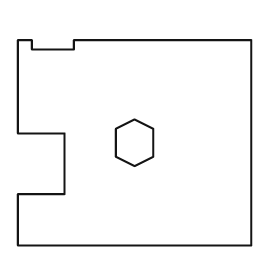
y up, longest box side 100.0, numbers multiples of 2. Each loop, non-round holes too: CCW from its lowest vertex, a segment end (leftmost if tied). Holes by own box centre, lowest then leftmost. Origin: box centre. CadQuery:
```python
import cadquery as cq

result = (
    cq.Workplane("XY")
    .moveTo(-50.0, -44.0)
    .lineTo(50.0, -44.0)
    .lineTo(50.0, 44.0)
    .lineTo(-26.0, 44.0)
    .lineTo(-26.0, 40.0)
    .lineTo(-44.0, 40.0)
    .lineTo(-44.0, 44.0)
    .lineTo(-50.0, 44.0)
    .lineTo(-50.0, 4.0)
    .lineTo(-30.0, 4.0)
    .lineTo(-30.0, -22.0)
    .lineTo(-50.0, -22.0)
    .close()
    .moveTo(0.0, -10.0)
    .lineTo(8.0, -6.0)
    .lineTo(8.0, 6.0)
    .lineTo(0.0, 10.0)
    .lineTo(-8.0, 6.0)
    .lineTo(-8.0, -6.0)
    .close()
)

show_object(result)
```